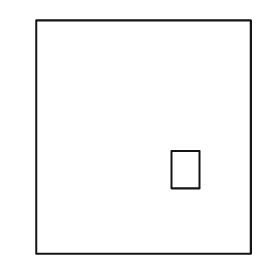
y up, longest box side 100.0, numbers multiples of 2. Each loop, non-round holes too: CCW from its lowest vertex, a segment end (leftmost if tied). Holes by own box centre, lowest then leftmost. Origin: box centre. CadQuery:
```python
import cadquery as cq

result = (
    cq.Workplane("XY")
    .moveTo(-46.0, -50.0)
    .lineTo(46.0, -50.0)
    .lineTo(46.0, 50.0)
    .lineTo(-46.0, 50.0)
    .close()
    .moveTo(12.0, -22.0)
    .lineTo(24.0, -22.0)
    .lineTo(24.0, -6.0)
    .lineTo(12.0, -6.0)
    .close()
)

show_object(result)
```